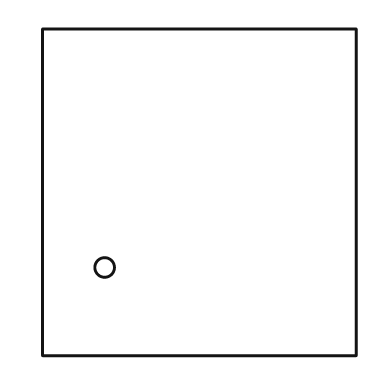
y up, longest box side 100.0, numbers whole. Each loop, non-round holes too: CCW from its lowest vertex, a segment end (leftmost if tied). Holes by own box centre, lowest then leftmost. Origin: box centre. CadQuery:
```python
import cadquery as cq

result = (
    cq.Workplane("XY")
    .moveTo(-48.0, -50.0)
    .lineTo(48.0, -50.0)
    .lineTo(48.0, 50.0)
    .lineTo(-48.0, 50.0)
    .close()
    .moveTo(-29.0, -23.0)
    .circle(3.0)
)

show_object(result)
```